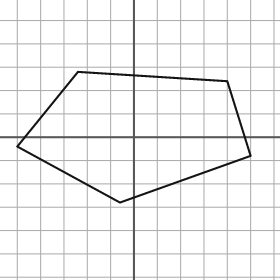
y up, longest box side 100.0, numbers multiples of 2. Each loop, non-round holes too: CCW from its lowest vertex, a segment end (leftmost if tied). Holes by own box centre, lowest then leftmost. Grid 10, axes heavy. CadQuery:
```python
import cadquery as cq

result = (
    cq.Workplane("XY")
    .moveTo(-6.0, -28.0)
    .lineTo(50.0, -8.0)
    .lineTo(40.0, 24.0)
    .lineTo(-24.0, 28.0)
    .lineTo(-50.0, -4.0)
    .close()
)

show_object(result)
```